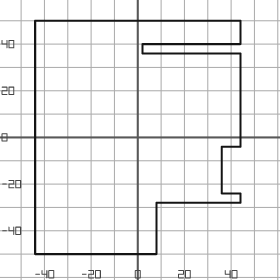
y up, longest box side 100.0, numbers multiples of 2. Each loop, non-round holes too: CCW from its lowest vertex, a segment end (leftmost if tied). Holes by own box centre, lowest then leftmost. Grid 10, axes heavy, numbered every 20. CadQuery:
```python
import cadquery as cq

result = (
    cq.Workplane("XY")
    .moveTo(-44.0, -50.0)
    .lineTo(8.0, -50.0)
    .lineTo(8.0, -28.0)
    .lineTo(44.0, -28.0)
    .lineTo(44.0, -24.0)
    .lineTo(36.0, -24.0)
    .lineTo(36.0, -4.0)
    .lineTo(44.0, -4.0)
    .lineTo(44.0, 36.0)
    .lineTo(2.0, 36.0)
    .lineTo(2.0, 40.0)
    .lineTo(44.0, 40.0)
    .lineTo(44.0, 50.0)
    .lineTo(-44.0, 50.0)
    .close()
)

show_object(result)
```